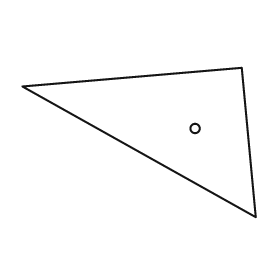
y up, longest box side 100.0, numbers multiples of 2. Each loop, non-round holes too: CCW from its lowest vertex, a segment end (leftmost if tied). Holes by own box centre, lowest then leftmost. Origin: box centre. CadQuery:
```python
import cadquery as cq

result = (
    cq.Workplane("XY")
    .moveTo(50.0, -32.0)
    .lineTo(44.0, 32.0)
    .lineTo(-50.0, 24.0)
    .close()
    .moveTo(24.0, 6.0)
    .circle(2.0)
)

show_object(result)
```